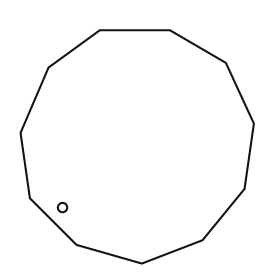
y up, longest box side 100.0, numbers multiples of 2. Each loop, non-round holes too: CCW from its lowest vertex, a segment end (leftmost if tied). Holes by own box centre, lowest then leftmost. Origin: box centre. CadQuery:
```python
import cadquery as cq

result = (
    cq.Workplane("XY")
    .moveTo(2.0, -50.0)
    .lineTo(28.0, -40.0)
    .lineTo(46.0, -18.0)
    .lineTo(50.0, 10.0)
    .lineTo(38.0, 36.0)
    .lineTo(14.0, 50.0)
    .lineTo(-16.0, 50.0)
    .lineTo(-38.0, 34.0)
    .lineTo(-50.0, 6.0)
    .lineTo(-46.0, -22.0)
    .lineTo(-26.0, -42.0)
    .close()
    .moveTo(-32.0, -26.0)
    .circle(2.0)
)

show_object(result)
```